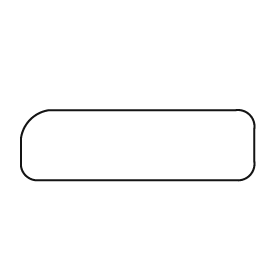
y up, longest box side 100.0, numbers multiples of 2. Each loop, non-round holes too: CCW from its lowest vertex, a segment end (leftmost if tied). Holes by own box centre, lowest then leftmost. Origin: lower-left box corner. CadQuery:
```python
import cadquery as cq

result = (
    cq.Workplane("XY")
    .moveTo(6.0, 0.0)
    .lineTo(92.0, 0.0)
    .threePointArc((98.0, 2.0), (100.0, 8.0))
    .lineTo(100.0, 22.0)
    .threePointArc((98.0, 28.0), (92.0, 30.0))
    .lineTo(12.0, 30.0)
    .threePointArc((4.0, 26.0), (0.0, 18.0))
    .lineTo(0.0, 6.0)
    .threePointArc((2.0, 2.0), (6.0, 0.0))
    .close()
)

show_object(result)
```